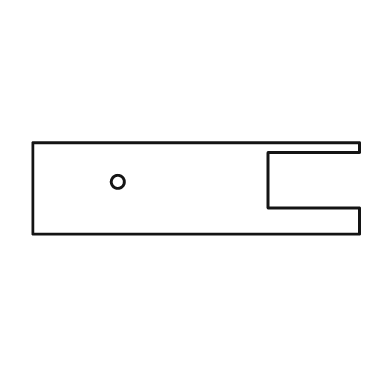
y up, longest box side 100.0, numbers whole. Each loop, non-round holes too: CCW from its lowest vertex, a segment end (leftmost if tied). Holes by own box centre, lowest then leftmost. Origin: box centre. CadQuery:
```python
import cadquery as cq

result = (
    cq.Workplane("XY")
    .moveTo(-50.0, -14.0)
    .lineTo(50.0, -14.0)
    .lineTo(50.0, -6.0)
    .lineTo(22.0, -6.0)
    .lineTo(22.0, 11.0)
    .lineTo(50.0, 11.0)
    .lineTo(50.0, 14.0)
    .lineTo(-50.0, 14.0)
    .close()
    .moveTo(-24.0, 2.0)
    .circle(2.0)
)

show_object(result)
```